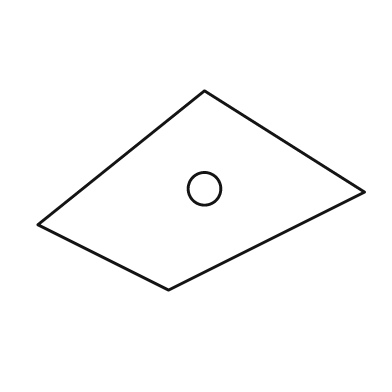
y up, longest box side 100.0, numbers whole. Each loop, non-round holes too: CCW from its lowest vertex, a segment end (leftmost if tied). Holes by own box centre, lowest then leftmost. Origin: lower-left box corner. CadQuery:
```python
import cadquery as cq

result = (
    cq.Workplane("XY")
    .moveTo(40.0, 0.0)
    .lineTo(100.0, 30.0)
    .lineTo(51.0, 61.0)
    .lineTo(0.0, 20.0)
    .close()
    .moveTo(51.0, 31.0)
    .circle(5.0)
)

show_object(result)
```